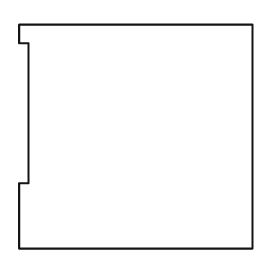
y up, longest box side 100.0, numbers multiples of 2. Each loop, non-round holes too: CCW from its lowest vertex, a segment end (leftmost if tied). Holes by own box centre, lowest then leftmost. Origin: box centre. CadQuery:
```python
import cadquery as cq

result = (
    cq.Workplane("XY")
    .moveTo(-50.0, -48.0)
    .lineTo(50.0, -48.0)
    .lineTo(50.0, 48.0)
    .lineTo(-50.0, 48.0)
    .lineTo(-50.0, 40.0)
    .lineTo(-46.0, 40.0)
    .lineTo(-46.0, -20.0)
    .lineTo(-50.0, -20.0)
    .close()
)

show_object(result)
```